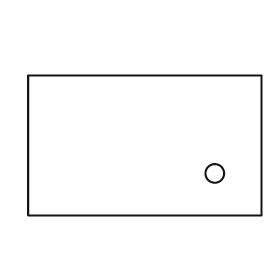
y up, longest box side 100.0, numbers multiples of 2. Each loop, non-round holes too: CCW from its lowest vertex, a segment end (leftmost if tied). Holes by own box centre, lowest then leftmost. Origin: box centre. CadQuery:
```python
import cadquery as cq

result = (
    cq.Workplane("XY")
    .moveTo(-50.0, -30.0)
    .lineTo(50.0, -30.0)
    .lineTo(50.0, 30.0)
    .lineTo(-50.0, 30.0)
    .close()
    .moveTo(30.0, -12.0)
    .circle(4.0)
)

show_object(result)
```